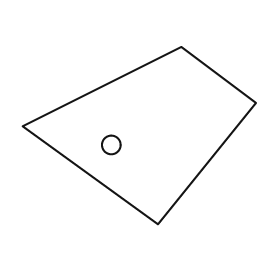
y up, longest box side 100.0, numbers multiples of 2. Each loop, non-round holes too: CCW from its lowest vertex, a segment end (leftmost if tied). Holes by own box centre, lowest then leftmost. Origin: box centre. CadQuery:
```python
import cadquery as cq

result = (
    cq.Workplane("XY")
    .moveTo(8.0, -38.0)
    .lineTo(50.0, 14.0)
    .lineTo(18.0, 38.0)
    .lineTo(-50.0, 4.0)
    .close()
    .moveTo(-12.0, -4.0)
    .circle(4.0)
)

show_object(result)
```